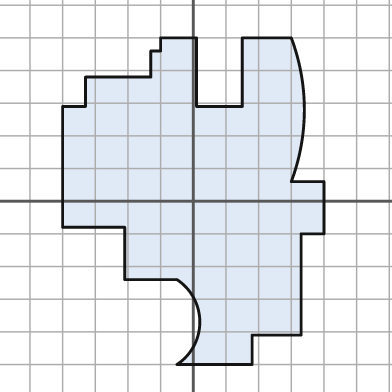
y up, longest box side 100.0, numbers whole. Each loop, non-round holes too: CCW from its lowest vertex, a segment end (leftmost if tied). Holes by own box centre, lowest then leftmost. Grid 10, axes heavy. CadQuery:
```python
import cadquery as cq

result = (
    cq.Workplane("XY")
    .moveTo(-5.0, -50.0)
    .lineTo(18.0, -50.0)
    .lineTo(18.0, -41.0)
    .lineTo(33.0, -41.0)
    .lineTo(33.0, -10.0)
    .lineTo(40.0, -10.0)
    .lineTo(40.0, 6.0)
    .lineTo(30.0, 6.0)
    .threePointArc((34.0, 28.0), (30.0, 50.0))
    .lineTo(15.0, 50.0)
    .lineTo(15.0, 29.0)
    .lineTo(1.0, 29.0)
    .lineTo(1.0, 50.0)
    .lineTo(-10.0, 50.0)
    .lineTo(-10.0, 46.0)
    .lineTo(-13.0, 46.0)
    .lineTo(-13.0, 38.0)
    .lineTo(-33.0, 38.0)
    .lineTo(-33.0, 29.0)
    .lineTo(-40.0, 29.0)
    .lineTo(-40.0, -8.0)
    .lineTo(-21.0, -8.0)
    .lineTo(-21.0, -24.0)
    .lineTo(-5.0, -24.0)
    .threePointArc((2.0, -37.0), (-5.0, -50.0))
    .close()
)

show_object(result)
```